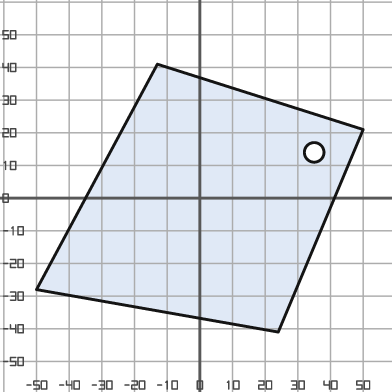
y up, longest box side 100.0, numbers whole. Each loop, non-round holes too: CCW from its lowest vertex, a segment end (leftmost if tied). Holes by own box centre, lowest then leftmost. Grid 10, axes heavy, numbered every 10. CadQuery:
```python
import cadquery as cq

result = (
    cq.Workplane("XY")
    .moveTo(24.0, -41.0)
    .lineTo(50.0, 21.0)
    .lineTo(-13.0, 41.0)
    .lineTo(-50.0, -28.0)
    .close()
    .moveTo(35.0, 14.0)
    .circle(3.0)
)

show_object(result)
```